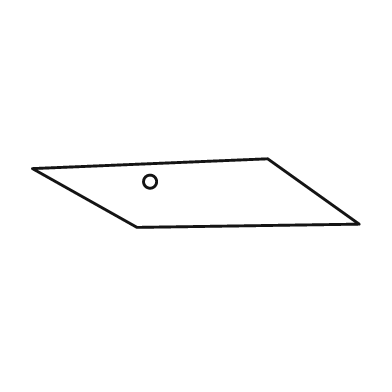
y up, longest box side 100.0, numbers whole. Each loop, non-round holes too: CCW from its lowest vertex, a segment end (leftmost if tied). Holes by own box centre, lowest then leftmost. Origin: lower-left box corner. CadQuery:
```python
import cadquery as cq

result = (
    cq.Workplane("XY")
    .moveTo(32.0, 0.0)
    .lineTo(100.0, 1.0)
    .lineTo(72.0, 21.0)
    .lineTo(0.0, 18.0)
    .close()
    .moveTo(36.0, 14.0)
    .circle(2.0)
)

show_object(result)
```